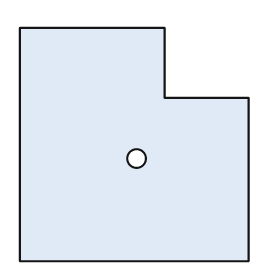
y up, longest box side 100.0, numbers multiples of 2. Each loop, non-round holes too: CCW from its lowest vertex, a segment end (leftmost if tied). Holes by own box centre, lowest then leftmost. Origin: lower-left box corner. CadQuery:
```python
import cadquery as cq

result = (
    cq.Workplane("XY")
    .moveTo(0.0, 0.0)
    .lineTo(98.0, 0.0)
    .lineTo(98.0, 70.0)
    .lineTo(62.0, 70.0)
    .lineTo(62.0, 100.0)
    .lineTo(0.0, 100.0)
    .close()
    .moveTo(50.0, 44.0)
    .circle(4.0)
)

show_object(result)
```